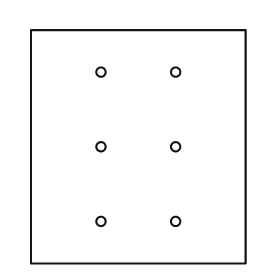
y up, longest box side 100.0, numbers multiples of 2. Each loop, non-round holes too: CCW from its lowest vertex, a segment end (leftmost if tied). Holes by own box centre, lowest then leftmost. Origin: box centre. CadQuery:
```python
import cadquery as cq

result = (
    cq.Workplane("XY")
    .moveTo(-46.0, -50.0)
    .lineTo(46.0, -50.0)
    .lineTo(46.0, 50.0)
    .lineTo(-46.0, 50.0)
    .close()
    .moveTo(-16.0, -32.0)
    .circle(2.0)
    .moveTo(16.0, -32.0)
    .circle(2.0)
    .moveTo(-16.0, 0.0)
    .circle(2.0)
    .moveTo(16.0, 0.0)
    .circle(2.0)
    .moveTo(-16.0, 32.0)
    .circle(2.0)
    .moveTo(16.0, 32.0)
    .circle(2.0)
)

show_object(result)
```